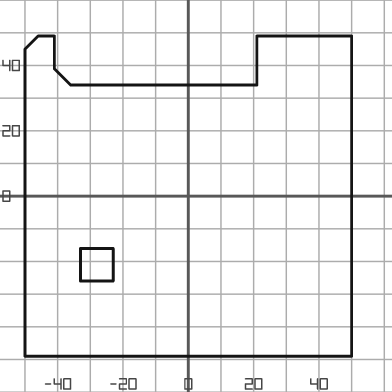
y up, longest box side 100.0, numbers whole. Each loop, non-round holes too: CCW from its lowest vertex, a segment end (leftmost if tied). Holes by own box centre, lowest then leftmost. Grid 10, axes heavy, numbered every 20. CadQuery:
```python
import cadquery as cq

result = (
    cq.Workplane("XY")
    .moveTo(-50.0, -49.0)
    .lineTo(50.0, -49.0)
    .lineTo(50.0, 49.0)
    .lineTo(21.0, 49.0)
    .lineTo(21.0, 34.0)
    .lineTo(-36.0, 34.0)
    .lineTo(-41.0, 39.0)
    .lineTo(-41.0, 49.0)
    .lineTo(-46.0, 49.0)
    .lineTo(-50.0, 45.0)
    .close()
    .moveTo(-33.0, -26.0)
    .lineTo(-23.0, -26.0)
    .lineTo(-23.0, -16.0)
    .lineTo(-33.0, -16.0)
    .close()
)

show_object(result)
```